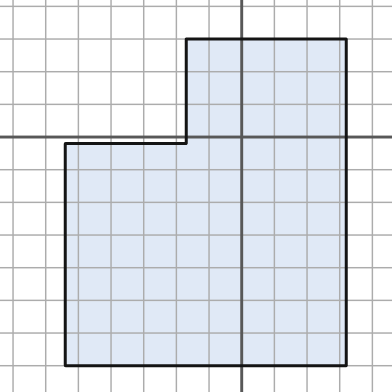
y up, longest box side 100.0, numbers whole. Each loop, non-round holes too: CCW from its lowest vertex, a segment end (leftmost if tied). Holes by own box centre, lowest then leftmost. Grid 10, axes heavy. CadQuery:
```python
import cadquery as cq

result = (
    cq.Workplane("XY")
    .moveTo(-54.0, -70.0)
    .lineTo(32.0, -70.0)
    .lineTo(32.0, 30.0)
    .lineTo(-17.0, 30.0)
    .lineTo(-17.0, -2.0)
    .lineTo(-54.0, -2.0)
    .close()
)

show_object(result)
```